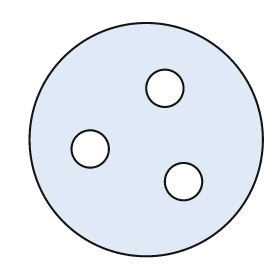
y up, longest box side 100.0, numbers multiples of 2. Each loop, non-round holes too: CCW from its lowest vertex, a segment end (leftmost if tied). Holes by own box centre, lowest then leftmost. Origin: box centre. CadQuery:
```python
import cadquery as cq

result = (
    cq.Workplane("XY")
    .moveTo(0.0, 0.0)
    .circle(50.0)
    .moveTo(16.0, -18.0)
    .circle(8.0)
    .moveTo(-24.0, -4.0)
    .circle(8.0)
    .moveTo(8.0, 22.0)
    .circle(8.0)
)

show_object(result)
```